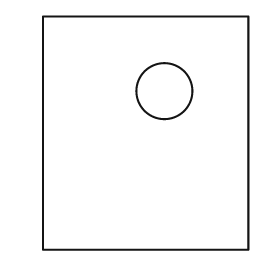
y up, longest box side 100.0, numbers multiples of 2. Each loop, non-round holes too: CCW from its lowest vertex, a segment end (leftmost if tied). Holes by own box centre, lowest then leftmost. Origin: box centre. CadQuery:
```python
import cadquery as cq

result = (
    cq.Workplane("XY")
    .moveTo(-44.0, -50.0)
    .lineTo(44.0, -50.0)
    .lineTo(44.0, 50.0)
    .lineTo(-44.0, 50.0)
    .close()
    .moveTo(8.0, 18.0)
    .circle(12.0)
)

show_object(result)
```